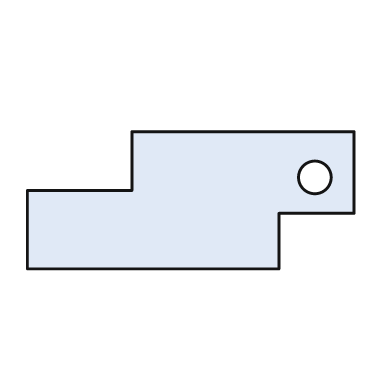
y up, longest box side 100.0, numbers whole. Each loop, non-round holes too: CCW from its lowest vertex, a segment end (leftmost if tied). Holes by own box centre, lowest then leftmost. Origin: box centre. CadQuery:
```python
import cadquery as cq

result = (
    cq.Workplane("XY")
    .moveTo(-50.0, -21.0)
    .lineTo(27.0, -21.0)
    .lineTo(27.0, -4.0)
    .lineTo(50.0, -4.0)
    .lineTo(50.0, 21.0)
    .lineTo(-18.0, 21.0)
    .lineTo(-18.0, 3.0)
    .lineTo(-50.0, 3.0)
    .close()
    .moveTo(38.0, 7.0)
    .circle(5.0)
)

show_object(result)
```